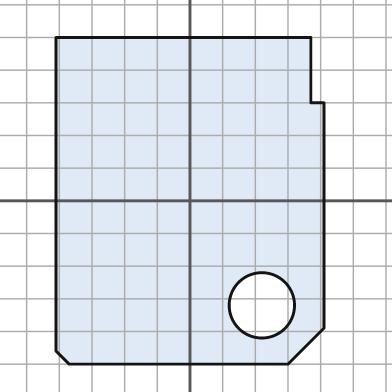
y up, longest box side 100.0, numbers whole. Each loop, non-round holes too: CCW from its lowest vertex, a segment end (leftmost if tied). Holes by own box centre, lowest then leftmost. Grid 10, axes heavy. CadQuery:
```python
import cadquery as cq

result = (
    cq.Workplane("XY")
    .moveTo(-37.0, -50.0)
    .lineTo(30.0, -50.0)
    .lineTo(41.0, -39.0)
    .lineTo(41.0, 30.0)
    .lineTo(37.0, 30.0)
    .lineTo(37.0, 50.0)
    .lineTo(-41.0, 50.0)
    .lineTo(-41.0, -46.0)
    .close()
    .moveTo(22.0, -32.0)
    .circle(10.0)
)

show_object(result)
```